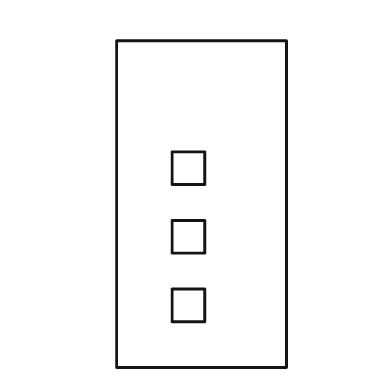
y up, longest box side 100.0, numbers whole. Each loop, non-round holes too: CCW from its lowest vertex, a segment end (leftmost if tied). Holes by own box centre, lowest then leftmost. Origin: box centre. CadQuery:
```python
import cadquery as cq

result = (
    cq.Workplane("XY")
    .moveTo(-26.0, -50.0)
    .lineTo(26.0, -50.0)
    .lineTo(26.0, 50.0)
    .lineTo(-26.0, 50.0)
    .close()
    .moveTo(-9.0, -36.0)
    .lineTo(1.0, -36.0)
    .lineTo(1.0, -26.0)
    .lineTo(-9.0, -26.0)
    .close()
    .moveTo(-9.0, -15.0)
    .lineTo(1.0, -15.0)
    .lineTo(1.0, -5.0)
    .lineTo(-9.0, -5.0)
    .close()
    .moveTo(-9.0, 6.0)
    .lineTo(1.0, 6.0)
    .lineTo(1.0, 16.0)
    .lineTo(-9.0, 16.0)
    .close()
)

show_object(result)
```